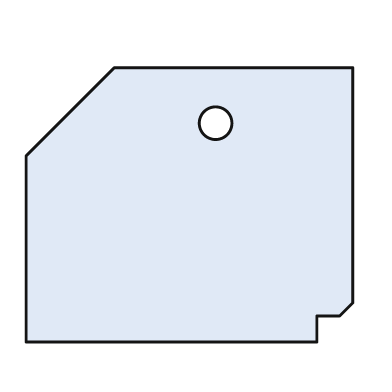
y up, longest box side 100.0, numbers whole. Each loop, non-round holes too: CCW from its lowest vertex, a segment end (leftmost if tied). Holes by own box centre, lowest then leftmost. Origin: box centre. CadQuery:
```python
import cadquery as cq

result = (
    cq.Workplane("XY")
    .moveTo(-50.0, -42.0)
    .lineTo(39.0, -42.0)
    .lineTo(39.0, -34.0)
    .lineTo(46.0, -34.0)
    .lineTo(50.0, -30.0)
    .lineTo(50.0, 42.0)
    .lineTo(-23.0, 42.0)
    .lineTo(-50.0, 15.0)
    .close()
    .moveTo(8.0, 25.0)
    .circle(5.0)
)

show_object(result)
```